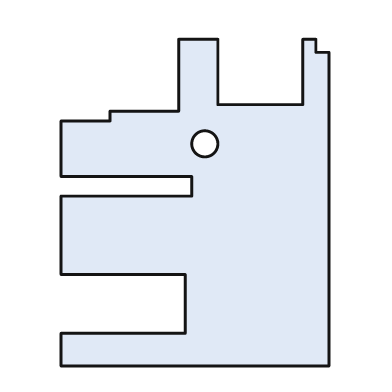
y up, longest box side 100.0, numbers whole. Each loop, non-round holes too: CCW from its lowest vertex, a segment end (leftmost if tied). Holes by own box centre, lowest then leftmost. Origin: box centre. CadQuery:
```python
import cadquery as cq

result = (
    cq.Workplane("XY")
    .moveTo(-41.0, -50.0)
    .lineTo(41.0, -50.0)
    .lineTo(41.0, 46.0)
    .lineTo(37.0, 46.0)
    .lineTo(37.0, 50.0)
    .lineTo(33.0, 50.0)
    .lineTo(33.0, 30.0)
    .lineTo(7.0, 30.0)
    .lineTo(7.0, 50.0)
    .lineTo(-5.0, 50.0)
    .lineTo(-5.0, 28.0)
    .lineTo(-26.0, 28.0)
    .lineTo(-26.0, 25.0)
    .lineTo(-41.0, 25.0)
    .lineTo(-41.0, 8.0)
    .lineTo(-1.0, 8.0)
    .lineTo(-1.0, 2.0)
    .lineTo(-41.0, 2.0)
    .lineTo(-41.0, -22.0)
    .lineTo(-3.0, -22.0)
    .lineTo(-3.0, -40.0)
    .lineTo(-41.0, -40.0)
    .close()
    .moveTo(3.0, 18.0)
    .circle(4.0)
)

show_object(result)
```